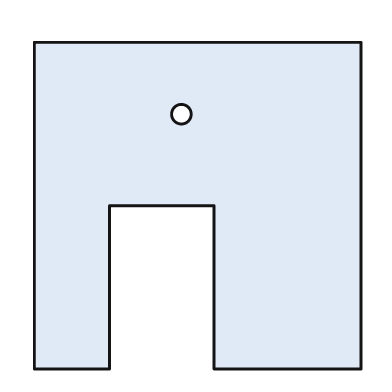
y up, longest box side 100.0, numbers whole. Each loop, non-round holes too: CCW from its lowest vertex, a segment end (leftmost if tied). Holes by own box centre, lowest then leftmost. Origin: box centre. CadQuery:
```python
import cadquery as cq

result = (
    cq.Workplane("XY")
    .moveTo(-50.0, -50.0)
    .lineTo(-27.0, -50.0)
    .lineTo(-27.0, 0.0)
    .lineTo(5.0, 0.0)
    .lineTo(5.0, -50.0)
    .lineTo(50.0, -50.0)
    .lineTo(50.0, 50.0)
    .lineTo(-50.0, 50.0)
    .close()
    .moveTo(-5.0, 28.0)
    .circle(3.0)
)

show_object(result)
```